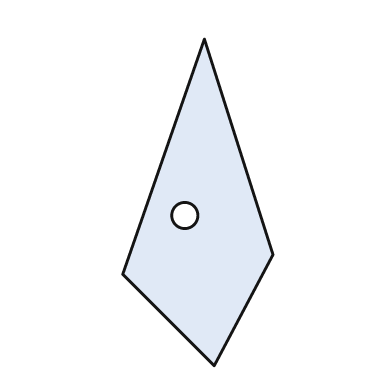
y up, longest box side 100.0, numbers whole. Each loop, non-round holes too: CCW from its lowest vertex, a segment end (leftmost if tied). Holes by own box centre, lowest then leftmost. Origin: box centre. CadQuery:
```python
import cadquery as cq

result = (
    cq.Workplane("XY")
    .moveTo(5.0, -50.0)
    .lineTo(23.0, -16.0)
    .lineTo(2.0, 50.0)
    .lineTo(-23.0, -22.0)
    .close()
    .moveTo(-4.0, -4.0)
    .circle(4.0)
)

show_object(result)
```